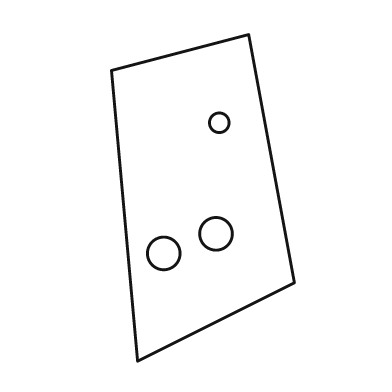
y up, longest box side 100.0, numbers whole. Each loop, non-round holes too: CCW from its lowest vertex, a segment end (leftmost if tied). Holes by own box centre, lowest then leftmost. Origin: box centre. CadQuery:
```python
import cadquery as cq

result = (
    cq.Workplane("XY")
    .moveTo(-20.0, -50.0)
    .lineTo(28.0, -26.0)
    .lineTo(14.0, 50.0)
    .lineTo(-28.0, 39.0)
    .close()
    .moveTo(-12.0, -17.0)
    .circle(5.0)
    .moveTo(4.0, -11.0)
    .circle(5.0)
    .moveTo(5.0, 23.0)
    .circle(3.0)
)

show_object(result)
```